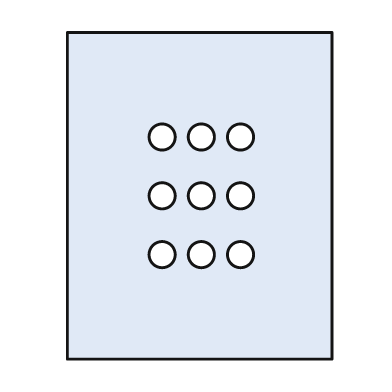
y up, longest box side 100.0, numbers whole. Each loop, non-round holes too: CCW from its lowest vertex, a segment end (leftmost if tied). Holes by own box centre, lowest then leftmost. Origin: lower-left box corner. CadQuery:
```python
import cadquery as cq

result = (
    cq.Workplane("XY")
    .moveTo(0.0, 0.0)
    .lineTo(81.0, 0.0)
    .lineTo(81.0, 100.0)
    .lineTo(0.0, 100.0)
    .close()
    .moveTo(29.0, 32.0)
    .circle(4.0)
    .moveTo(41.0, 32.0)
    .circle(4.0)
    .moveTo(53.0, 32.0)
    .circle(4.0)
    .moveTo(29.0, 50.0)
    .circle(4.0)
    .moveTo(41.0, 50.0)
    .circle(4.0)
    .moveTo(53.0, 50.0)
    .circle(4.0)
    .moveTo(29.0, 68.0)
    .circle(4.0)
    .moveTo(41.0, 68.0)
    .circle(4.0)
    .moveTo(53.0, 68.0)
    .circle(4.0)
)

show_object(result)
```